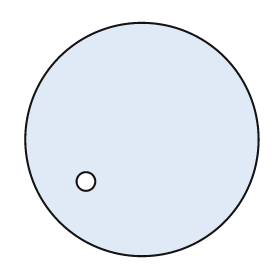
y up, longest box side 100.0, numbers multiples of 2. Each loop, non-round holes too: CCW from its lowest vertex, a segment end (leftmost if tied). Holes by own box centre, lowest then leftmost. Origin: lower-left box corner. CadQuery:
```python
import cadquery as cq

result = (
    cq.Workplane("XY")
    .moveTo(50.0, 50.0)
    .circle(50.0)
    .moveTo(26.0, 32.0)
    .circle(4.0)
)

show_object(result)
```